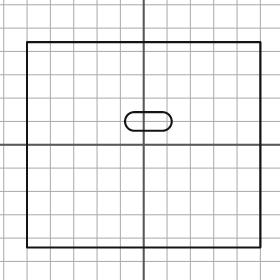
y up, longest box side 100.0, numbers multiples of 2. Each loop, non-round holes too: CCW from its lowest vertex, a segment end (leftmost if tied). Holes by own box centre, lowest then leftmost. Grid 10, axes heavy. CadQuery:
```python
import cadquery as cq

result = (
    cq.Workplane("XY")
    .moveTo(-50.0, -44.0)
    .lineTo(50.0, -44.0)
    .lineTo(50.0, 44.0)
    .lineTo(-50.0, 44.0)
    .close()
    .moveTo(-4.0, 6.0)
    .lineTo(8.0, 6.0)
    .threePointArc((12.0, 10.0), (8.0, 14.0))
    .lineTo(-4.0, 14.0)
    .threePointArc((-8.0, 10.0), (-4.0, 6.0))
    .close()
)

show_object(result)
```